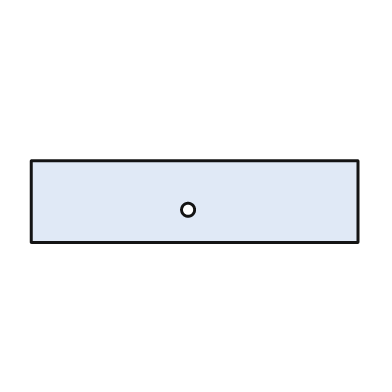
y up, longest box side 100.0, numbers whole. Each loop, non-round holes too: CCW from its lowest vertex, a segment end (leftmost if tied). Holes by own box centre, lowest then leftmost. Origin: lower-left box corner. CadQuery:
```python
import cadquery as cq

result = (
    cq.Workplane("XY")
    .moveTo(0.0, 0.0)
    .lineTo(100.0, 0.0)
    .lineTo(100.0, 25.0)
    .lineTo(0.0, 25.0)
    .close()
    .moveTo(48.0, 10.0)
    .circle(2.0)
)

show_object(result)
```